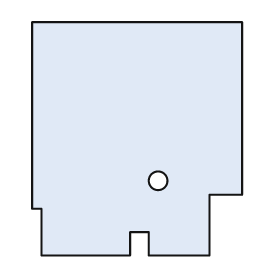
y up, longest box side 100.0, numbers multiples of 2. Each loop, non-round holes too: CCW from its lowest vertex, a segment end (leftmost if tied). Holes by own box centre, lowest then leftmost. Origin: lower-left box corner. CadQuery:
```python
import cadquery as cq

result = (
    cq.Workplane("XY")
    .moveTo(4.0, 0.0)
    .lineTo(42.0, 0.0)
    .lineTo(42.0, 10.0)
    .lineTo(50.0, 10.0)
    .lineTo(50.0, 0.0)
    .lineTo(76.0, 0.0)
    .lineTo(76.0, 26.0)
    .lineTo(90.0, 26.0)
    .lineTo(90.0, 100.0)
    .lineTo(0.0, 100.0)
    .lineTo(0.0, 20.0)
    .lineTo(4.0, 20.0)
    .close()
    .moveTo(54.0, 32.0)
    .circle(4.0)
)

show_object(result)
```